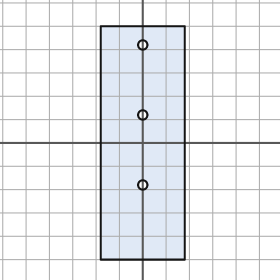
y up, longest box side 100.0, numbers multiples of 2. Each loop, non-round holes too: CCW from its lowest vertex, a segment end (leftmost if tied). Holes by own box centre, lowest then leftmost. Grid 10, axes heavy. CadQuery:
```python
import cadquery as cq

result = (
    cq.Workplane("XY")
    .moveTo(-18.0, -50.0)
    .lineTo(18.0, -50.0)
    .lineTo(18.0, 50.0)
    .lineTo(-18.0, 50.0)
    .close()
    .moveTo(0.0, -18.0)
    .circle(2.0)
    .moveTo(0.0, 12.0)
    .circle(2.0)
    .moveTo(0.0, 42.0)
    .circle(2.0)
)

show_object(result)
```